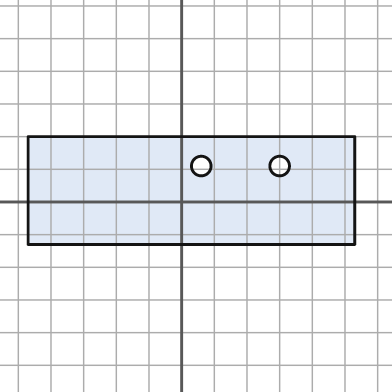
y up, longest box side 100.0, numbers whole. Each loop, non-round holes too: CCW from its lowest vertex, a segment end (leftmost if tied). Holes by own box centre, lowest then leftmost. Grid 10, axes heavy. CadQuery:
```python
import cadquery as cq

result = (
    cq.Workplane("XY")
    .moveTo(-47.0, -13.0)
    .lineTo(53.0, -13.0)
    .lineTo(53.0, 20.0)
    .lineTo(-47.0, 20.0)
    .close()
    .moveTo(6.0, 11.0)
    .circle(3.0)
    .moveTo(30.0, 11.0)
    .circle(3.0)
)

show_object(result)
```